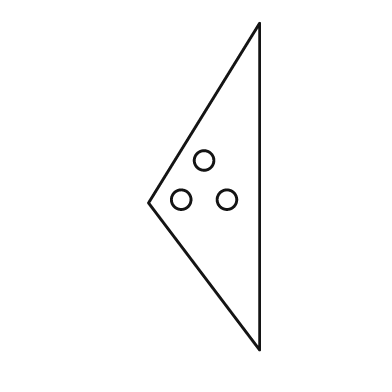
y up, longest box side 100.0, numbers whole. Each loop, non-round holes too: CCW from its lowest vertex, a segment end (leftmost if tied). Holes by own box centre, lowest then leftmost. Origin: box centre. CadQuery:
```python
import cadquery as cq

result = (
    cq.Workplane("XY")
    .moveTo(17.0, -50.0)
    .lineTo(17.0, 50.0)
    .lineTo(-17.0, -5.0)
    .close()
    .moveTo(-7.0, -4.0)
    .circle(3.0)
    .moveTo(7.0, -4.0)
    .circle(3.0)
    .moveTo(0.0, 8.0)
    .circle(3.0)
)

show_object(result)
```